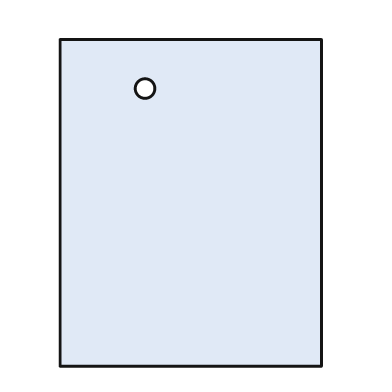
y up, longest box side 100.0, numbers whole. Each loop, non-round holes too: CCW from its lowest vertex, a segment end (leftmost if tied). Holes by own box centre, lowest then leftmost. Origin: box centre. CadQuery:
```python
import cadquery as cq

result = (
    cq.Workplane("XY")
    .moveTo(-40.0, -50.0)
    .lineTo(40.0, -50.0)
    .lineTo(40.0, 50.0)
    .lineTo(-40.0, 50.0)
    .close()
    .moveTo(-14.0, 35.0)
    .circle(3.0)
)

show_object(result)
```